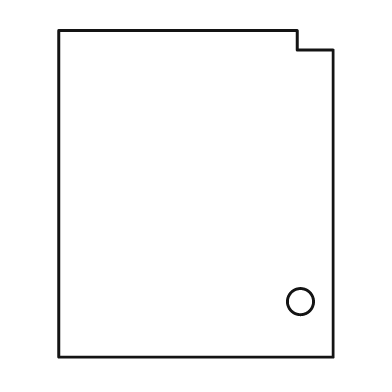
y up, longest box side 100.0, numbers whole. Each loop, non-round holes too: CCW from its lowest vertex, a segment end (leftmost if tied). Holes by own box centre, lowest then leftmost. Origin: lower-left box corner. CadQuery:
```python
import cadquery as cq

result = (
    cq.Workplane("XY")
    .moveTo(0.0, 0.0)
    .lineTo(84.0, 0.0)
    .lineTo(84.0, 94.0)
    .lineTo(73.0, 94.0)
    .lineTo(73.0, 100.0)
    .lineTo(0.0, 100.0)
    .close()
    .moveTo(74.0, 17.0)
    .circle(4.0)
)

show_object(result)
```